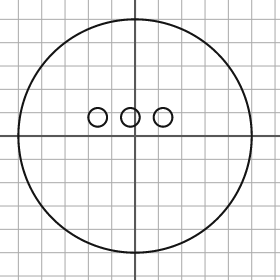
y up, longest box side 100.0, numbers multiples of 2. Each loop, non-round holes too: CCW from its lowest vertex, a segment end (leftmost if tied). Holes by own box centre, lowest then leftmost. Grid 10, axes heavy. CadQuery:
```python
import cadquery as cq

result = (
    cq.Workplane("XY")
    .moveTo(0.0, 0.0)
    .circle(50.0)
    .moveTo(-16.0, 8.0)
    .circle(4.0)
    .moveTo(-2.0, 8.0)
    .circle(4.0)
    .moveTo(12.0, 8.0)
    .circle(4.0)
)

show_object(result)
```